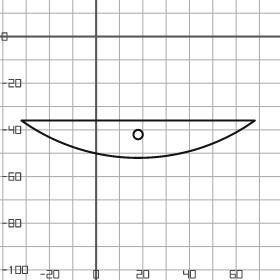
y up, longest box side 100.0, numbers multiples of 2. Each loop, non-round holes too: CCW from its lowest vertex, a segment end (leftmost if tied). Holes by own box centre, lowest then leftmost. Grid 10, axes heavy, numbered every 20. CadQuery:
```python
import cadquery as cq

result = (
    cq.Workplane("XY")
    .moveTo(-32.0, -36.0)
    .threePointArc((18.0, -52.0), (68.0, -36.0))
    .close()
    .moveTo(18.0, -42.0)
    .circle(2.0)
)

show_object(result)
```